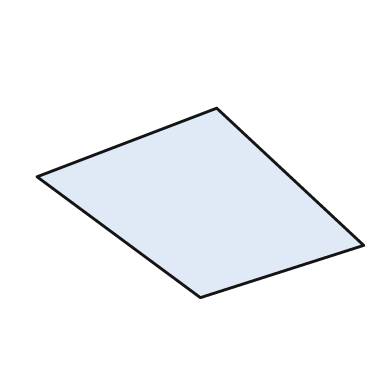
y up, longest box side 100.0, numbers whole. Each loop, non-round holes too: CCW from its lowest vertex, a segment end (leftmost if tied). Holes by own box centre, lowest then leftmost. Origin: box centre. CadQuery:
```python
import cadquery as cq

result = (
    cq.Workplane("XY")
    .moveTo(0.0, -29.0)
    .lineTo(50.0, -13.0)
    .lineTo(5.0, 29.0)
    .lineTo(-50.0, 8.0)
    .close()
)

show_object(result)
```